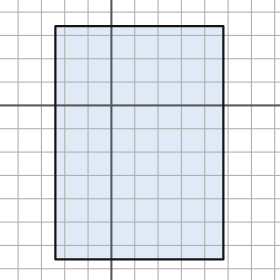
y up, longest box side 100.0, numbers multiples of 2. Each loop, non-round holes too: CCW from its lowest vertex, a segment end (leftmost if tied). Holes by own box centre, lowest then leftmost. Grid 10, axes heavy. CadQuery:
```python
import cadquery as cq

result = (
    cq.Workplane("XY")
    .moveTo(-24.0, -66.0)
    .lineTo(48.0, -66.0)
    .lineTo(48.0, 34.0)
    .lineTo(-24.0, 34.0)
    .close()
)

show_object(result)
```